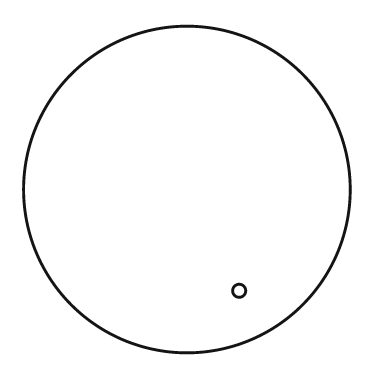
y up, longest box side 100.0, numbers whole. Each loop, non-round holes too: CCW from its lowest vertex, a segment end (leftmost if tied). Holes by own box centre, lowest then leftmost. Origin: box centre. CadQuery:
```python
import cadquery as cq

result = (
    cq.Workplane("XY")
    .moveTo(0.0, 0.0)
    .circle(50.0)
    .moveTo(16.0, -31.0)
    .circle(2.0)
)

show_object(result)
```